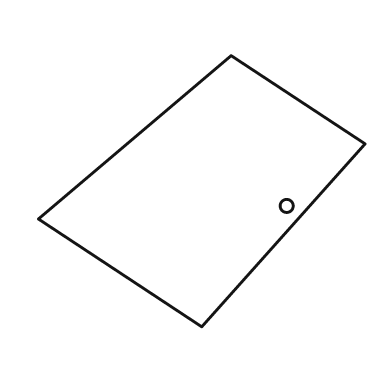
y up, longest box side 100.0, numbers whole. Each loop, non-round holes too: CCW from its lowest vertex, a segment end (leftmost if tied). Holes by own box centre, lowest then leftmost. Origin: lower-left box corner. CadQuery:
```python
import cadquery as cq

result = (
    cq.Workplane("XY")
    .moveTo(50.0, 0.0)
    .lineTo(100.0, 56.0)
    .lineTo(59.0, 83.0)
    .lineTo(0.0, 33.0)
    .close()
    .moveTo(76.0, 37.0)
    .circle(2.0)
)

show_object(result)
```